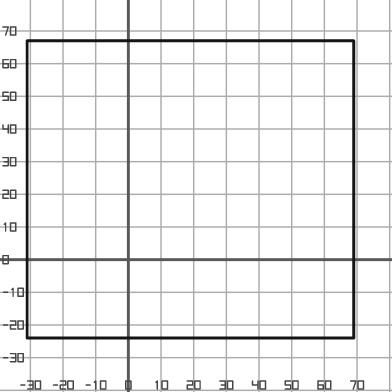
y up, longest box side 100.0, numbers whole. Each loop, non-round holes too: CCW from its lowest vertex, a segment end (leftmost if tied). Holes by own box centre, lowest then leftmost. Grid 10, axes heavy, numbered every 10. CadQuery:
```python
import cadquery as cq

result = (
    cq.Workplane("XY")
    .moveTo(-31.0, -24.0)
    .lineTo(69.0, -24.0)
    .lineTo(69.0, 67.0)
    .lineTo(-31.0, 67.0)
    .close()
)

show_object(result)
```